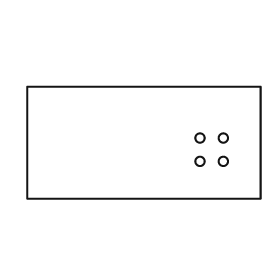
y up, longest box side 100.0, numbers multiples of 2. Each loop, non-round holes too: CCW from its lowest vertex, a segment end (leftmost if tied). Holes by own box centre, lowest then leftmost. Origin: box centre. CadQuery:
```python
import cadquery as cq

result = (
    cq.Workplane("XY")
    .moveTo(-50.0, -24.0)
    .lineTo(50.0, -24.0)
    .lineTo(50.0, 24.0)
    .lineTo(-50.0, 24.0)
    .close()
    .moveTo(24.0, -8.0)
    .circle(2.0)
    .moveTo(34.0, -8.0)
    .circle(2.0)
    .moveTo(24.0, 2.0)
    .circle(2.0)
    .moveTo(34.0, 2.0)
    .circle(2.0)
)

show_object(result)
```